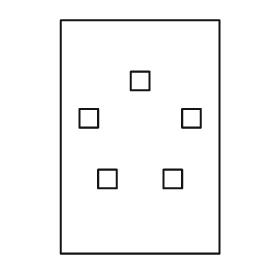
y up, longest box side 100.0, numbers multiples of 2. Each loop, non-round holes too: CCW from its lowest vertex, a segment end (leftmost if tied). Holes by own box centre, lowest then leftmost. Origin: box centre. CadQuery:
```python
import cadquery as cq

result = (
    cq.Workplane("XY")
    .moveTo(-34.0, -50.0)
    .lineTo(34.0, -50.0)
    .lineTo(34.0, 50.0)
    .lineTo(-34.0, 50.0)
    .close()
    .moveTo(-18.0, -22.0)
    .lineTo(-10.0, -22.0)
    .lineTo(-10.0, -14.0)
    .lineTo(-18.0, -14.0)
    .close()
    .moveTo(10.0, -22.0)
    .lineTo(18.0, -22.0)
    .lineTo(18.0, -14.0)
    .lineTo(10.0, -14.0)
    .close()
    .moveTo(-26.0, 4.0)
    .lineTo(-18.0, 4.0)
    .lineTo(-18.0, 12.0)
    .lineTo(-26.0, 12.0)
    .close()
    .moveTo(18.0, 4.0)
    .lineTo(26.0, 4.0)
    .lineTo(26.0, 12.0)
    .lineTo(18.0, 12.0)
    .close()
    .moveTo(-4.0, 20.0)
    .lineTo(4.0, 20.0)
    .lineTo(4.0, 28.0)
    .lineTo(-4.0, 28.0)
    .close()
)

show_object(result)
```